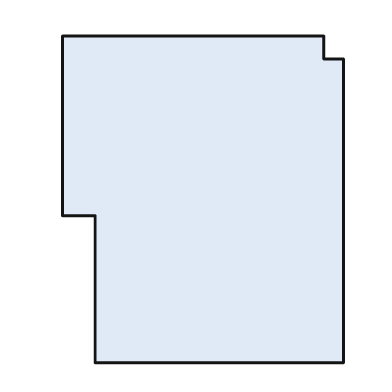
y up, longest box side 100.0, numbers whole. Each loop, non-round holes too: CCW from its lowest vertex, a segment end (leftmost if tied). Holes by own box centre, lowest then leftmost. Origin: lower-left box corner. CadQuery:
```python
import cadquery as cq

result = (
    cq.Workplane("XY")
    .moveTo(10.0, 0.0)
    .lineTo(86.0, 0.0)
    .lineTo(86.0, 93.0)
    .lineTo(80.0, 93.0)
    .lineTo(80.0, 100.0)
    .lineTo(0.0, 100.0)
    .lineTo(0.0, 45.0)
    .lineTo(10.0, 45.0)
    .close()
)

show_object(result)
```